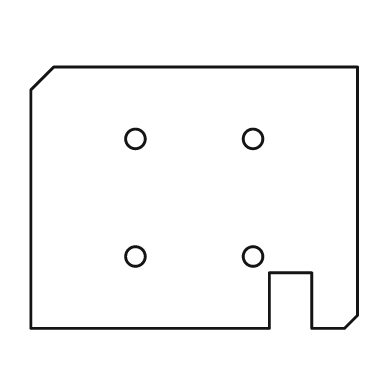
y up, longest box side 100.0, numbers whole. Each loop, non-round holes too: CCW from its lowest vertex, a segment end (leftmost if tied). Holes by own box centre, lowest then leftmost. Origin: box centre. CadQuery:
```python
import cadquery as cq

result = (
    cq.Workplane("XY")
    .moveTo(-50.0, -40.0)
    .lineTo(23.0, -40.0)
    .lineTo(23.0, -23.0)
    .lineTo(36.0, -23.0)
    .lineTo(36.0, -40.0)
    .lineTo(46.0, -40.0)
    .lineTo(50.0, -36.0)
    .lineTo(50.0, 40.0)
    .lineTo(-43.0, 40.0)
    .lineTo(-50.0, 33.0)
    .close()
    .moveTo(-18.0, -18.0)
    .circle(3.0)
    .moveTo(18.0, -18.0)
    .circle(3.0)
    .moveTo(-18.0, 18.0)
    .circle(3.0)
    .moveTo(18.0, 18.0)
    .circle(3.0)
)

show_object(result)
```